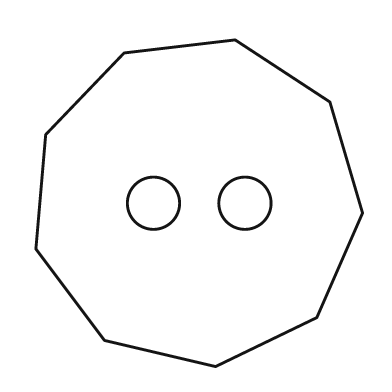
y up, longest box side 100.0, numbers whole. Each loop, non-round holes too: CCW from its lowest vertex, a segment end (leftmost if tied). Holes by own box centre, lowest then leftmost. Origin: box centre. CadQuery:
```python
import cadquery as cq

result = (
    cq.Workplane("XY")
    .moveTo(5.0, -50.0)
    .lineTo(36.0, -35.0)
    .lineTo(50.0, -3.0)
    .lineTo(40.0, 31.0)
    .lineTo(11.0, 50.0)
    .lineTo(-23.0, 46.0)
    .lineTo(-47.0, 21.0)
    .lineTo(-50.0, -14.0)
    .lineTo(-29.0, -42.0)
    .close()
    .moveTo(-14.0, 0.0)
    .circle(8.0)
    .moveTo(14.0, 0.0)
    .circle(8.0)
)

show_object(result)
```